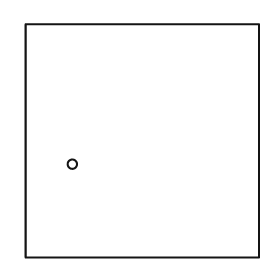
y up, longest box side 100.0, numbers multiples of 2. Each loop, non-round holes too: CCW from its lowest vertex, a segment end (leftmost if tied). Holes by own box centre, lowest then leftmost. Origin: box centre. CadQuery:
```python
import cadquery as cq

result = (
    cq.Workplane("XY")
    .moveTo(-50.0, -50.0)
    .lineTo(50.0, -50.0)
    .lineTo(50.0, 50.0)
    .lineTo(-50.0, 50.0)
    .close()
    .moveTo(-30.0, -10.0)
    .circle(2.0)
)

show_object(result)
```